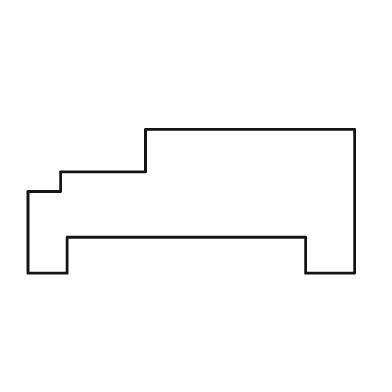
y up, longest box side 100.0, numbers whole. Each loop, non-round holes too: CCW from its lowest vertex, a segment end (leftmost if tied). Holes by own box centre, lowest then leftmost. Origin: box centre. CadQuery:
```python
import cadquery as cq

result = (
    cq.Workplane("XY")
    .moveTo(-50.0, -22.0)
    .lineTo(-38.0, -22.0)
    .lineTo(-38.0, -11.0)
    .lineTo(35.0, -11.0)
    .lineTo(35.0, -22.0)
    .lineTo(50.0, -22.0)
    .lineTo(50.0, 22.0)
    .lineTo(-14.0, 22.0)
    .lineTo(-14.0, 9.0)
    .lineTo(-40.0, 9.0)
    .lineTo(-40.0, 3.0)
    .lineTo(-50.0, 3.0)
    .close()
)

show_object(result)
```